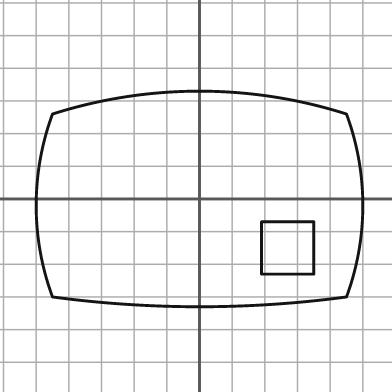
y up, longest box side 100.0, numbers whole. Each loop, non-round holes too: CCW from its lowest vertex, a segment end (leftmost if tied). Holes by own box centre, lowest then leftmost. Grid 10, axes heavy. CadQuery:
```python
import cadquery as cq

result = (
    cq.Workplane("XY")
    .moveTo(-45.0, -30.0)
    .threePointArc((0.0, -33.0), (45.0, -30.0))
    .threePointArc((50.0, -2.0), (45.0, 26.0))
    .threePointArc((0.0, 33.0), (-45.0, 26.0))
    .threePointArc((-50.0, -2.0), (-45.0, -30.0))
    .close()
    .moveTo(19.0, -23.0)
    .lineTo(35.0, -23.0)
    .lineTo(35.0, -7.0)
    .lineTo(19.0, -7.0)
    .close()
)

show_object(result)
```